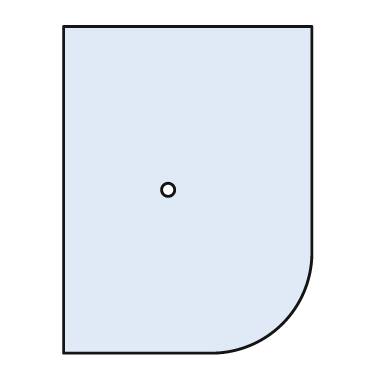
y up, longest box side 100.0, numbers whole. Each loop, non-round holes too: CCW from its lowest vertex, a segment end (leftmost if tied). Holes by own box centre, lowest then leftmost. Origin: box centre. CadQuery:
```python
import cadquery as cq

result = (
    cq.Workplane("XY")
    .moveTo(-38.0, -50.0)
    .lineTo(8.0, -50.0)
    .threePointArc((29.0, -41.0), (38.0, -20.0))
    .lineTo(38.0, 50.0)
    .lineTo(-38.0, 50.0)
    .close()
    .moveTo(-6.0, 0.0)
    .circle(2.0)
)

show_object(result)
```